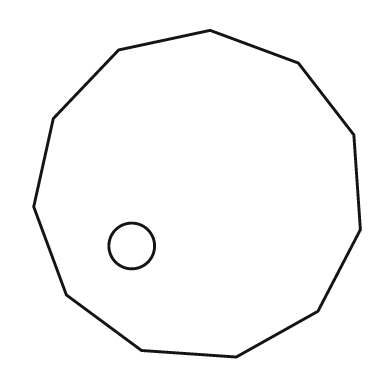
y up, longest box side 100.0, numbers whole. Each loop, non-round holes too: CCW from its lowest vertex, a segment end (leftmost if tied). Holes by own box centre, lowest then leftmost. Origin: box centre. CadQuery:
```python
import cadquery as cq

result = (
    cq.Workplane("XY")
    .moveTo(12.0, -50.0)
    .lineTo(37.0, -36.0)
    .lineTo(50.0, -11.0)
    .lineTo(48.0, 18.0)
    .lineTo(31.0, 40.0)
    .lineTo(4.0, 50.0)
    .lineTo(-24.0, 44.0)
    .lineTo(-44.0, 23.0)
    .lineTo(-50.0, -4.0)
    .lineTo(-40.0, -31.0)
    .lineTo(-17.0, -48.0)
    .close()
    .moveTo(-20.0, -16.0)
    .circle(7.0)
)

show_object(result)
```